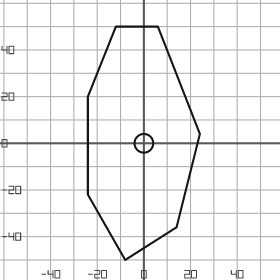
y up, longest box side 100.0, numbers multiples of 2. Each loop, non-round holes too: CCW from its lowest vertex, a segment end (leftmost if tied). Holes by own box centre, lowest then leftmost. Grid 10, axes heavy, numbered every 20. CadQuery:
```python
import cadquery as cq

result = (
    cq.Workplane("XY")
    .moveTo(-8.0, -50.0)
    .lineTo(14.0, -36.0)
    .lineTo(24.0, 4.0)
    .lineTo(6.0, 50.0)
    .lineTo(-12.0, 50.0)
    .lineTo(-24.0, 20.0)
    .lineTo(-24.0, -22.0)
    .close()
    .moveTo(0.0, 0.0)
    .circle(4.0)
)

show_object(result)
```